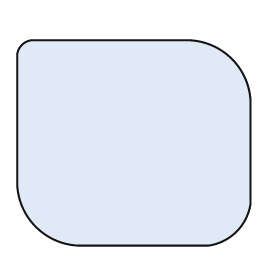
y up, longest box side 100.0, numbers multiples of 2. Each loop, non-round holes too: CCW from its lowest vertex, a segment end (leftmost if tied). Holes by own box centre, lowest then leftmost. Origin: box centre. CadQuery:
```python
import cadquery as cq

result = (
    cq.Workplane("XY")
    .moveTo(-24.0, -44.0)
    .lineTo(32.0, -44.0)
    .threePointArc((44.0, -38.0), (50.0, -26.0))
    .lineTo(50.0, 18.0)
    .threePointArc((42.0, 36.0), (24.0, 44.0))
    .lineTo(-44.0, 44.0)
    .threePointArc((-48.0, 42.0), (-50.0, 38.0))
    .lineTo(-50.0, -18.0)
    .threePointArc((-42.0, -36.0), (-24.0, -44.0))
    .close()
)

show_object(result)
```